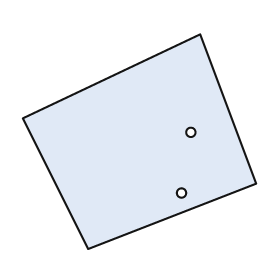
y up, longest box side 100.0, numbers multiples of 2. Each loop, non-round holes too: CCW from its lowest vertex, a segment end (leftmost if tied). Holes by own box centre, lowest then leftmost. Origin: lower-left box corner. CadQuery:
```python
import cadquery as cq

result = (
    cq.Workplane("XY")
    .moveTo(28.0, 0.0)
    .lineTo(100.0, 28.0)
    .lineTo(76.0, 92.0)
    .lineTo(0.0, 56.0)
    .close()
    .moveTo(68.0, 24.0)
    .circle(2.0)
    .moveTo(72.0, 50.0)
    .circle(2.0)
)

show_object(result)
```